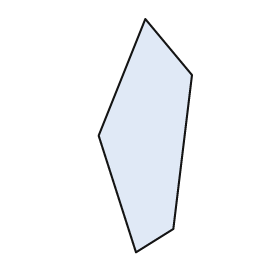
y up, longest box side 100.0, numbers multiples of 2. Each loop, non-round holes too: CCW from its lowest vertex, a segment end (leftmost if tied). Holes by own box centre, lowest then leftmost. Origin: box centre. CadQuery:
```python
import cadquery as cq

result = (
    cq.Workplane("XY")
    .moveTo(-4.0, -50.0)
    .lineTo(12.0, -40.0)
    .lineTo(20.0, 26.0)
    .lineTo(0.0, 50.0)
    .lineTo(-20.0, 0.0)
    .close()
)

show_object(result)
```